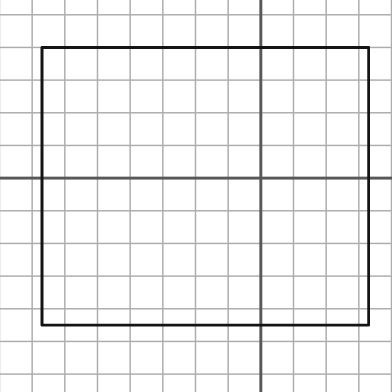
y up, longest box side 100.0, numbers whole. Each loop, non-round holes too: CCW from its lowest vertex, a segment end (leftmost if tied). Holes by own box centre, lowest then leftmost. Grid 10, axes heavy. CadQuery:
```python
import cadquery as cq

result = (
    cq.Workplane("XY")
    .moveTo(-67.0, -45.0)
    .lineTo(33.0, -45.0)
    .lineTo(33.0, 40.0)
    .lineTo(-67.0, 40.0)
    .close()
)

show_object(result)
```